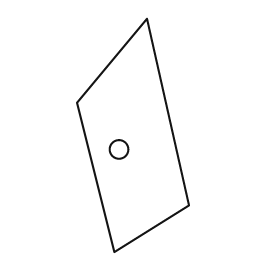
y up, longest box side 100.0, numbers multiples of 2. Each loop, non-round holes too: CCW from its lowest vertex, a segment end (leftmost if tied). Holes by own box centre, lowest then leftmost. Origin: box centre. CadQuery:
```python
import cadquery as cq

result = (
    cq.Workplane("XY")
    .moveTo(-8.0, -50.0)
    .lineTo(24.0, -30.0)
    .lineTo(6.0, 50.0)
    .lineTo(-24.0, 14.0)
    .close()
    .moveTo(-6.0, -6.0)
    .circle(4.0)
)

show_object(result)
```